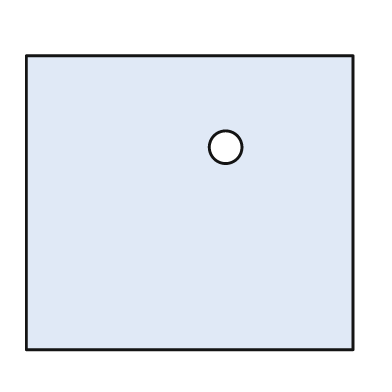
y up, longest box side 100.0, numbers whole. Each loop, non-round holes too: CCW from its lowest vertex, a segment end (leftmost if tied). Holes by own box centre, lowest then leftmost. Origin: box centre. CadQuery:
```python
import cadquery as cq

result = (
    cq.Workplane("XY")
    .moveTo(-50.0, -45.0)
    .lineTo(50.0, -45.0)
    .lineTo(50.0, 45.0)
    .lineTo(-50.0, 45.0)
    .close()
    .moveTo(11.0, 17.0)
    .circle(5.0)
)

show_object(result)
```